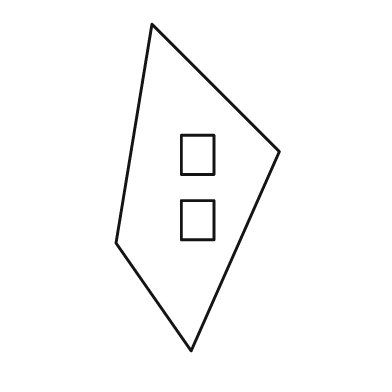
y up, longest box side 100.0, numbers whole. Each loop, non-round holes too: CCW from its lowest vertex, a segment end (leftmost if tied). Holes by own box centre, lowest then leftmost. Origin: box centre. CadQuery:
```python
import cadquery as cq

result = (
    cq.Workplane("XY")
    .moveTo(-2.0, -50.0)
    .lineTo(25.0, 11.0)
    .lineTo(-14.0, 50.0)
    .lineTo(-25.0, -17.0)
    .close()
    .moveTo(-5.0, -16.0)
    .lineTo(5.0, -16.0)
    .lineTo(5.0, -4.0)
    .lineTo(-5.0, -4.0)
    .close()
    .moveTo(-5.0, 4.0)
    .lineTo(5.0, 4.0)
    .lineTo(5.0, 16.0)
    .lineTo(-5.0, 16.0)
    .close()
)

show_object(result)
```